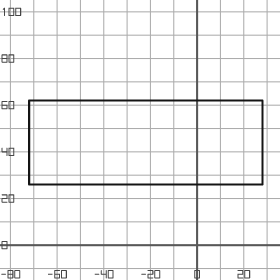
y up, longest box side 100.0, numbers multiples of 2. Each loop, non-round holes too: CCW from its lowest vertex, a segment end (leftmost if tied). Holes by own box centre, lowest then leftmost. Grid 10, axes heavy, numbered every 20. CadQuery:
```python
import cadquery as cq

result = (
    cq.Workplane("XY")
    .moveTo(-72.0, 26.0)
    .lineTo(28.0, 26.0)
    .lineTo(28.0, 62.0)
    .lineTo(-72.0, 62.0)
    .close()
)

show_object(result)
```